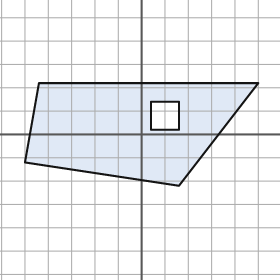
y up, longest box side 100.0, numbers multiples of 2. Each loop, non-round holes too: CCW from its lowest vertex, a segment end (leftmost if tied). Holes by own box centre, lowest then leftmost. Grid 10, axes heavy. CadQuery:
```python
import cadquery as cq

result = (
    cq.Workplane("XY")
    .moveTo(16.0, -22.0)
    .lineTo(50.0, 22.0)
    .lineTo(-44.0, 22.0)
    .lineTo(-50.0, -12.0)
    .close()
    .moveTo(4.0, 2.0)
    .lineTo(16.0, 2.0)
    .lineTo(16.0, 14.0)
    .lineTo(4.0, 14.0)
    .close()
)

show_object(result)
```